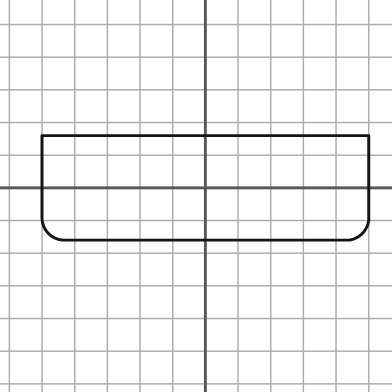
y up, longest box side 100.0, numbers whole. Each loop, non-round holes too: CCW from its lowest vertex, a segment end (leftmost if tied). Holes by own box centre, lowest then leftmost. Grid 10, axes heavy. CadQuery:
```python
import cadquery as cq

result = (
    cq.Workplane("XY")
    .moveTo(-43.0, -16.0)
    .lineTo(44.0, -16.0)
    .threePointArc((48.0, -14.0), (50.0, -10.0))
    .lineTo(50.0, 16.0)
    .lineTo(-50.0, 16.0)
    .lineTo(-50.0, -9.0)
    .threePointArc((-48.0, -14.0), (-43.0, -16.0))
    .close()
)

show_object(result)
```